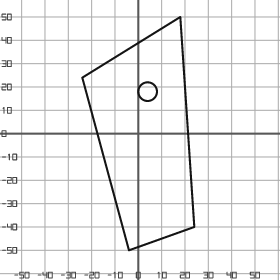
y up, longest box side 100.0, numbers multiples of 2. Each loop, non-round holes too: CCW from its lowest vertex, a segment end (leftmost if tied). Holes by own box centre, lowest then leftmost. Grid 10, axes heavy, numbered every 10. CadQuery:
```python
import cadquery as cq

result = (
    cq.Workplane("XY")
    .moveTo(-4.0, -50.0)
    .lineTo(24.0, -40.0)
    .lineTo(18.0, 50.0)
    .lineTo(-24.0, 24.0)
    .close()
    .moveTo(4.0, 18.0)
    .circle(4.0)
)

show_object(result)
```